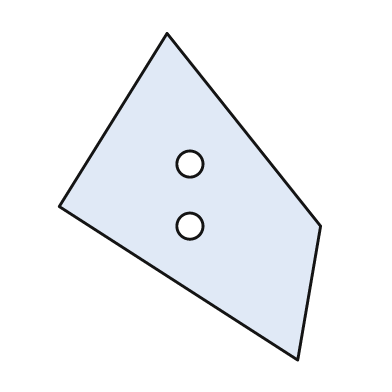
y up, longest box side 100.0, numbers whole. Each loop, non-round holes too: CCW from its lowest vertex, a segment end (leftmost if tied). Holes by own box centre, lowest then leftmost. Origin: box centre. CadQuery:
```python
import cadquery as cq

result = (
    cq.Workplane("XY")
    .moveTo(33.0, -50.0)
    .lineTo(40.0, -9.0)
    .lineTo(-7.0, 50.0)
    .lineTo(-40.0, -3.0)
    .close()
    .moveTo(0.0, -9.0)
    .circle(4.0)
    .moveTo(0.0, 10.0)
    .circle(4.0)
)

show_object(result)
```